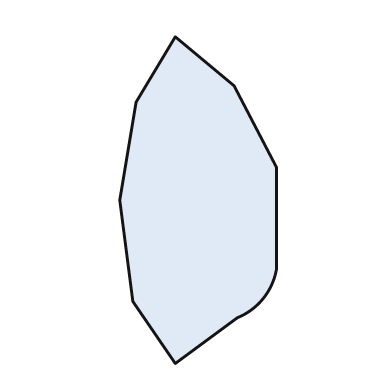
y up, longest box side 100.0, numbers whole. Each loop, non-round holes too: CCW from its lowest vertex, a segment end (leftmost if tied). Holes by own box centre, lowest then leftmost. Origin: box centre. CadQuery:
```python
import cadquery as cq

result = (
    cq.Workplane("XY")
    .moveTo(-7.0, -50.0)
    .lineTo(12.0, -36.0)
    .threePointArc((20.0, -30.0), (24.0, -21.0))
    .lineTo(24.0, 10.0)
    .lineTo(11.0, 35.0)
    .lineTo(-7.0, 50.0)
    .lineTo(-19.0, 30.0)
    .lineTo(-24.0, 0.0)
    .lineTo(-20.0, -31.0)
    .close()
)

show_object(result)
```